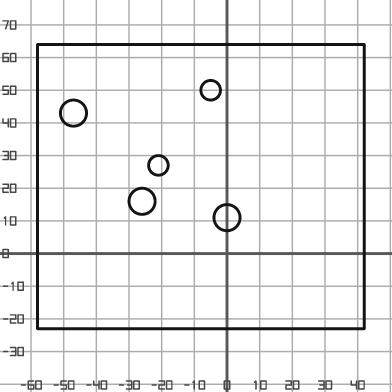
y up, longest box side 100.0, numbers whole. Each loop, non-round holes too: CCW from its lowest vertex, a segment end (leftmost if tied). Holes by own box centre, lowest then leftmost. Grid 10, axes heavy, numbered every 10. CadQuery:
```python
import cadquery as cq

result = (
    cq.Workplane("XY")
    .moveTo(-58.0, -23.0)
    .lineTo(42.0, -23.0)
    .lineTo(42.0, 64.0)
    .lineTo(-58.0, 64.0)
    .close()
    .moveTo(0.0, 11.0)
    .circle(4.0)
    .moveTo(-26.0, 16.0)
    .circle(4.0)
    .moveTo(-21.0, 27.0)
    .circle(3.0)
    .moveTo(-47.0, 43.0)
    .circle(4.0)
    .moveTo(-5.0, 50.0)
    .circle(3.0)
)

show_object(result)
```